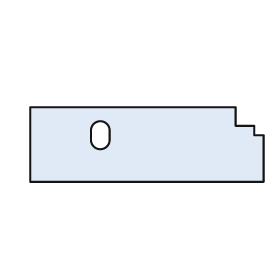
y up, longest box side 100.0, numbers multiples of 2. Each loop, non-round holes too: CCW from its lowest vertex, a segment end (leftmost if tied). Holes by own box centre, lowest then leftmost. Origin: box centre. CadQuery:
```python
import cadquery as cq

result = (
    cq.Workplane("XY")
    .moveTo(-50.0, -16.0)
    .lineTo(50.0, -16.0)
    .lineTo(50.0, 4.0)
    .lineTo(46.0, 4.0)
    .lineTo(46.0, 8.0)
    .lineTo(38.0, 8.0)
    .lineTo(38.0, 16.0)
    .lineTo(-50.0, 16.0)
    .close()
    .moveTo(-24.0, 2.0)
    .threePointArc((-20.0, -2.0), (-16.0, 2.0))
    .lineTo(-16.0, 6.0)
    .threePointArc((-20.0, 10.0), (-24.0, 6.0))
    .close()
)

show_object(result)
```